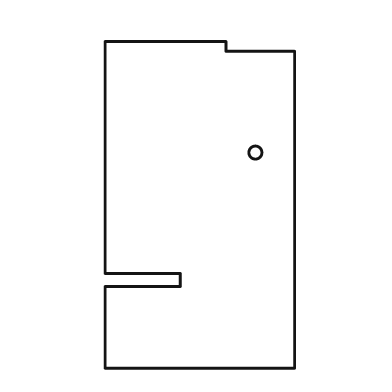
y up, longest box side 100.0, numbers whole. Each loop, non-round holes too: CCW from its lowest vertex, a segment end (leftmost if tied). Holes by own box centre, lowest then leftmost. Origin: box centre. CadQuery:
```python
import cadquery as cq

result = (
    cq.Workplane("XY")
    .moveTo(-29.0, -50.0)
    .lineTo(29.0, -50.0)
    .lineTo(29.0, 47.0)
    .lineTo(8.0, 47.0)
    .lineTo(8.0, 50.0)
    .lineTo(-29.0, 50.0)
    .lineTo(-29.0, -21.0)
    .lineTo(-6.0, -21.0)
    .lineTo(-6.0, -25.0)
    .lineTo(-29.0, -25.0)
    .close()
    .moveTo(17.0, 16.0)
    .circle(2.0)
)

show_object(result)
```